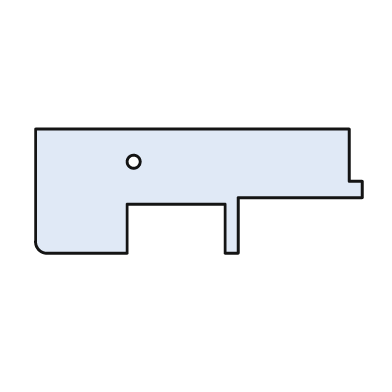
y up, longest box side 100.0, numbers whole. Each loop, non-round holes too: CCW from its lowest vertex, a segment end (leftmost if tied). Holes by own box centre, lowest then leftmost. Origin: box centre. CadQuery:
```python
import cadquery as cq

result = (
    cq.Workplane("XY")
    .moveTo(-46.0, -19.0)
    .lineTo(-22.0, -19.0)
    .lineTo(-22.0, -4.0)
    .lineTo(8.0, -4.0)
    .lineTo(8.0, -19.0)
    .lineTo(12.0, -19.0)
    .lineTo(12.0, -2.0)
    .lineTo(50.0, -2.0)
    .lineTo(50.0, 3.0)
    .lineTo(46.0, 3.0)
    .lineTo(46.0, 19.0)
    .lineTo(-50.0, 19.0)
    .lineTo(-50.0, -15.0)
    .threePointArc((-49.0, -18.0), (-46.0, -19.0))
    .close()
    .moveTo(-20.0, 9.0)
    .circle(2.0)
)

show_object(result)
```